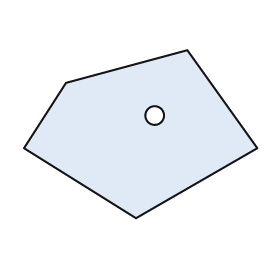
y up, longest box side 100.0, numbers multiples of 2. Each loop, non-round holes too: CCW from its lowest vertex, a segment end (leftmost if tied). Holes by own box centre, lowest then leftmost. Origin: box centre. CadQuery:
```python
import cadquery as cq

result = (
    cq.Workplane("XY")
    .moveTo(-2.0, -36.0)
    .lineTo(50.0, -6.0)
    .lineTo(20.0, 36.0)
    .lineTo(-32.0, 22.0)
    .lineTo(-50.0, -6.0)
    .close()
    .moveTo(6.0, 8.0)
    .circle(4.0)
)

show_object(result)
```